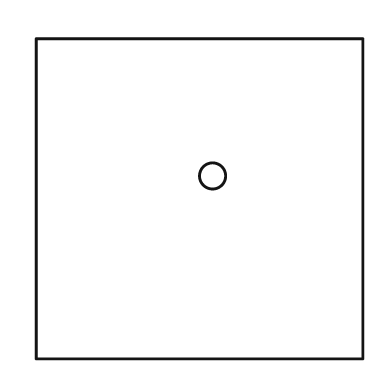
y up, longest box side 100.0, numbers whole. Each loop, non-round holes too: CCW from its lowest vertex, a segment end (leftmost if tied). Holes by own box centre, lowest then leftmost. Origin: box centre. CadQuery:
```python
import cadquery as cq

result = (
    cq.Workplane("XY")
    .moveTo(-50.0, -49.0)
    .lineTo(50.0, -49.0)
    .lineTo(50.0, 49.0)
    .lineTo(-50.0, 49.0)
    .close()
    .moveTo(4.0, 7.0)
    .circle(4.0)
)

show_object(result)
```